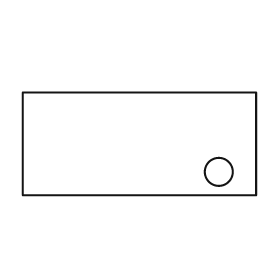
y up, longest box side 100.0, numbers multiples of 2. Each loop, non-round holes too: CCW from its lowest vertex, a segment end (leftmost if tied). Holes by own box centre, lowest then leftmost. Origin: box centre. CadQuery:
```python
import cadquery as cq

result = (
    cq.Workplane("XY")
    .moveTo(-50.0, -22.0)
    .lineTo(50.0, -22.0)
    .lineTo(50.0, 22.0)
    .lineTo(-50.0, 22.0)
    .close()
    .moveTo(34.0, -12.0)
    .circle(6.0)
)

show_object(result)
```